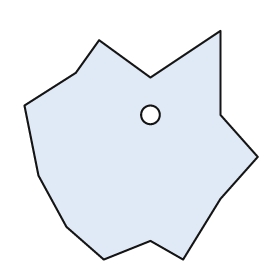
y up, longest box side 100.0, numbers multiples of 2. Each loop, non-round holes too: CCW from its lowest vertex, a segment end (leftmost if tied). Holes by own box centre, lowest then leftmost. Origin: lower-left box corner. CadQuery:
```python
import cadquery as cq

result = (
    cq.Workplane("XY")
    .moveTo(34.0, 0.0)
    .lineTo(54.0, 8.0)
    .lineTo(68.0, 0.0)
    .lineTo(84.0, 26.0)
    .lineTo(100.0, 44.0)
    .lineTo(84.0, 62.0)
    .lineTo(84.0, 98.0)
    .lineTo(54.0, 78.0)
    .lineTo(32.0, 94.0)
    .lineTo(22.0, 80.0)
    .lineTo(0.0, 66.0)
    .lineTo(6.0, 36.0)
    .lineTo(18.0, 14.0)
    .close()
    .moveTo(54.0, 62.0)
    .circle(4.0)
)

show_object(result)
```